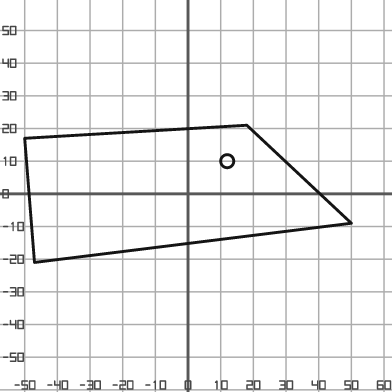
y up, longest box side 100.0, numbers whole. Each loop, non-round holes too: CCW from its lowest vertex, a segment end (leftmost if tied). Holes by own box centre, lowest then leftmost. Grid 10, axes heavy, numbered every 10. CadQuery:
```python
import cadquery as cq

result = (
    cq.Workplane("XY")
    .moveTo(-47.0, -21.0)
    .lineTo(50.0, -9.0)
    .lineTo(18.0, 21.0)
    .lineTo(-50.0, 17.0)
    .close()
    .moveTo(12.0, 10.0)
    .circle(2.0)
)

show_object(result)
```